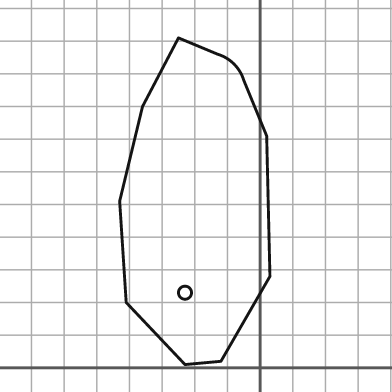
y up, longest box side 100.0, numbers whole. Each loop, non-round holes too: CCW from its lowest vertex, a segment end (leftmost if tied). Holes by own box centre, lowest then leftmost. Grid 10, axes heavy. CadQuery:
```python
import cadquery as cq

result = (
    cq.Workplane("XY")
    .moveTo(-23.0, 1.0)
    .lineTo(-12.0, 2.0)
    .lineTo(3.0, 28.0)
    .lineTo(2.0, 71.0)
    .lineTo(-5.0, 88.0)
    .threePointArc((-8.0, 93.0), (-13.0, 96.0))
    .lineTo(-25.0, 101.0)
    .lineTo(-36.0, 80.0)
    .lineTo(-43.0, 51.0)
    .lineTo(-41.0, 20.0)
    .close()
    .moveTo(-23.0, 23.0)
    .circle(2.0)
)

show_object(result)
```